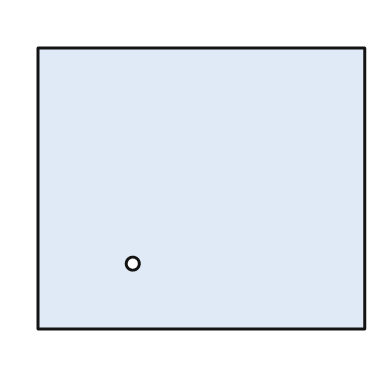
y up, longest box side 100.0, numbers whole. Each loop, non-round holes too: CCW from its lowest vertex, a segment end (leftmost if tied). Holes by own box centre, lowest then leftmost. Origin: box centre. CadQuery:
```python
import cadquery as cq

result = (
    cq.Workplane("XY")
    .moveTo(-50.0, -43.0)
    .lineTo(50.0, -43.0)
    .lineTo(50.0, 43.0)
    .lineTo(-50.0, 43.0)
    .close()
    .moveTo(-21.0, -23.0)
    .circle(2.0)
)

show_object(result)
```